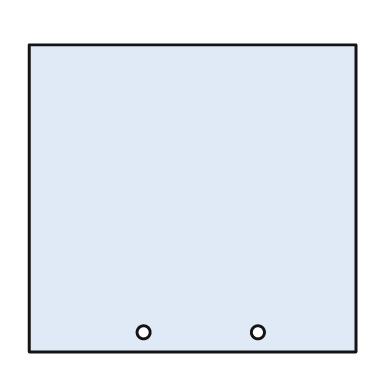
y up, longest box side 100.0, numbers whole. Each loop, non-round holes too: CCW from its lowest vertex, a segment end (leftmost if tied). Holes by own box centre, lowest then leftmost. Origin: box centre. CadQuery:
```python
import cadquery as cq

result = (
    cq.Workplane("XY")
    .moveTo(-50.0, -47.0)
    .lineTo(50.0, -47.0)
    .lineTo(50.0, 47.0)
    .lineTo(-50.0, 47.0)
    .close()
    .moveTo(-15.0, -41.0)
    .circle(2.0)
    .moveTo(20.0, -41.0)
    .circle(2.0)
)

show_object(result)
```